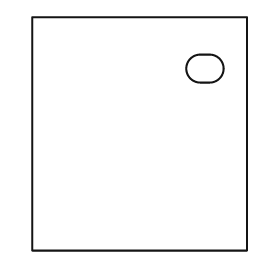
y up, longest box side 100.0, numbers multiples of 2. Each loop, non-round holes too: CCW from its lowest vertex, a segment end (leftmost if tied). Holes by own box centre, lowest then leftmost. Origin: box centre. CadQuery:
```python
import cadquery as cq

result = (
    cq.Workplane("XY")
    .moveTo(-46.0, -50.0)
    .lineTo(46.0, -50.0)
    .lineTo(46.0, 50.0)
    .lineTo(-46.0, 50.0)
    .close()
    .moveTo(26.0, 22.0)
    .lineTo(30.0, 22.0)
    .threePointArc((36.0, 28.0), (30.0, 34.0))
    .lineTo(26.0, 34.0)
    .threePointArc((20.0, 28.0), (26.0, 22.0))
    .close()
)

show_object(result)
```